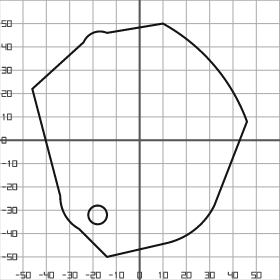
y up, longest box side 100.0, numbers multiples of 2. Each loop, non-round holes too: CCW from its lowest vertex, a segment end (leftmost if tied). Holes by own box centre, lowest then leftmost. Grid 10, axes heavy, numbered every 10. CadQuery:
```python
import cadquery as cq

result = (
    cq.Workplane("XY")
    .moveTo(-14.0, -50.0)
    .lineTo(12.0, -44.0)
    .threePointArc((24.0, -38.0), (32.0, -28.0))
    .lineTo(46.0, 8.0)
    .threePointArc((32.0, 32.0), (10.0, 50.0))
    .lineTo(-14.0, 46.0)
    .threePointArc((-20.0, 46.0), (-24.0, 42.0))
    .lineTo(-46.0, 22.0)
    .lineTo(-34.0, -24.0)
    .threePointArc((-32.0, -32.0), (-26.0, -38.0))
    .close()
    .moveTo(-18.0, -32.0)
    .circle(4.0)
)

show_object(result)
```